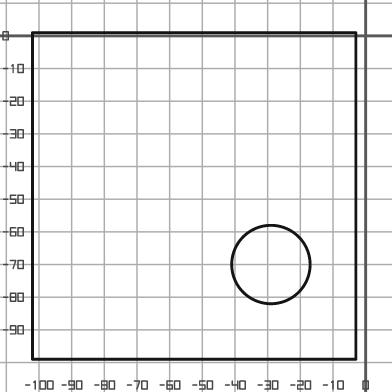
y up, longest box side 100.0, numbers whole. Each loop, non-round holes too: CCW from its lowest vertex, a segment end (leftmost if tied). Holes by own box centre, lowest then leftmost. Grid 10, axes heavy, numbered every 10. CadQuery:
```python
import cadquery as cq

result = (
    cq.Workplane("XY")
    .moveTo(-102.0, -99.0)
    .lineTo(-3.0, -99.0)
    .lineTo(-3.0, 1.0)
    .lineTo(-102.0, 1.0)
    .close()
    .moveTo(-29.0, -70.0)
    .circle(12.0)
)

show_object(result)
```